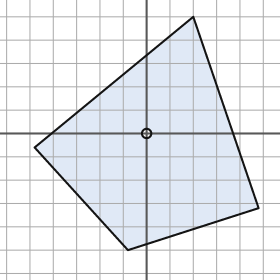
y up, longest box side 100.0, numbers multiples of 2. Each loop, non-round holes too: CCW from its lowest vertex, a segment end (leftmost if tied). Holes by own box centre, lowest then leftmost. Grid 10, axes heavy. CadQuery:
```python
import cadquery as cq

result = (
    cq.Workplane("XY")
    .moveTo(-8.0, -50.0)
    .lineTo(48.0, -32.0)
    .lineTo(20.0, 50.0)
    .lineTo(-48.0, -6.0)
    .close()
    .moveTo(0.0, 0.0)
    .circle(2.0)
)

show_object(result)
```